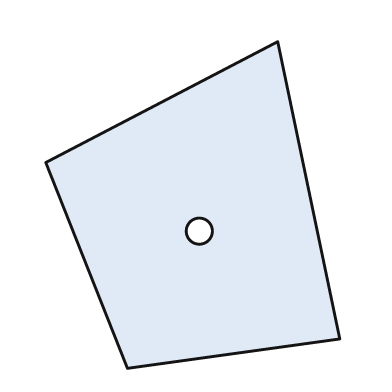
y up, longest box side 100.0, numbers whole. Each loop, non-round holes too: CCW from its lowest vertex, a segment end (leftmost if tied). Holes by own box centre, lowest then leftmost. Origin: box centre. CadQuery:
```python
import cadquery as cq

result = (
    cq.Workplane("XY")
    .moveTo(-20.0, -50.0)
    .lineTo(45.0, -41.0)
    .lineTo(26.0, 50.0)
    .lineTo(-45.0, 13.0)
    .close()
    .moveTo(2.0, -8.0)
    .circle(4.0)
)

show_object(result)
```